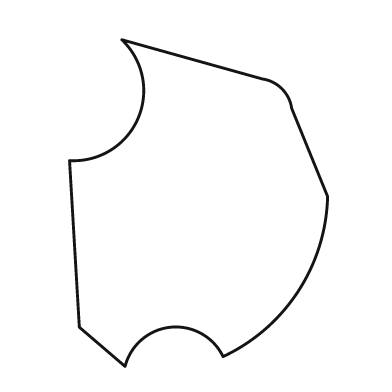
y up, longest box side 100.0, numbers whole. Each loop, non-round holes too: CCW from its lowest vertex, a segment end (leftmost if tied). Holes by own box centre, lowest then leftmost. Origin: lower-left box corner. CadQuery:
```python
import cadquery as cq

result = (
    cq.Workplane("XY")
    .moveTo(17.0, 0.0)
    .threePointArc((31.0, 12.0), (47.0, 3.0))
    .threePointArc((70.0, 23.0), (79.0, 52.0))
    .lineTo(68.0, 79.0)
    .threePointArc((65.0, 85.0), (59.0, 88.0))
    .lineTo(16.0, 100.0)
    .threePointArc((21.0, 76.0), (0.0, 63.0))
    .lineTo(3.0, 12.0)
    .close()
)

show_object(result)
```